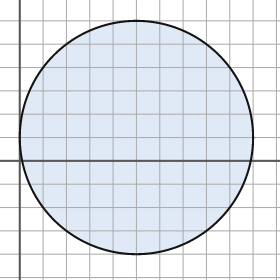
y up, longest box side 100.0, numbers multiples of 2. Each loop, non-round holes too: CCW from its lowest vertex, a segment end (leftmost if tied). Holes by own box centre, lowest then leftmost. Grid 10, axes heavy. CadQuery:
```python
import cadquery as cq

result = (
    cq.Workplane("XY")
    .moveTo(50.0, 10.0)
    .circle(50.0)
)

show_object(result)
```